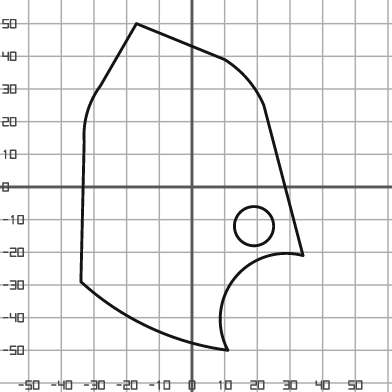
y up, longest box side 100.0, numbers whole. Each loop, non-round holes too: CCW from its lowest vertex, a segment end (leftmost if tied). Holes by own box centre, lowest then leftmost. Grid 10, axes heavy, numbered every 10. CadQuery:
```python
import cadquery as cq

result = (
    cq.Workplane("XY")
    .moveTo(11.0, -50.0)
    .threePointArc((13.0, -28.0), (34.0, -21.0))
    .lineTo(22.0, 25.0)
    .threePointArc((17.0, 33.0), (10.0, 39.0))
    .lineTo(-17.0, 50.0)
    .lineTo(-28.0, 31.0)
    .threePointArc((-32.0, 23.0), (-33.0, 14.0))
    .lineTo(-34.0, -29.0)
    .threePointArc((-13.0, -43.0), (11.0, -50.0))
    .close()
    .moveTo(19.0, -12.0)
    .circle(6.0)
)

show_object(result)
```